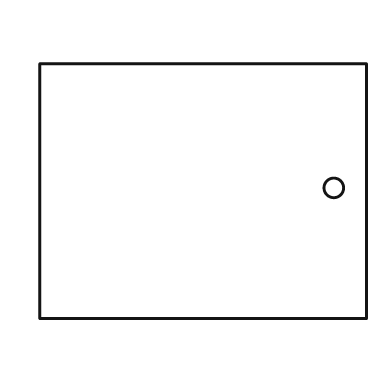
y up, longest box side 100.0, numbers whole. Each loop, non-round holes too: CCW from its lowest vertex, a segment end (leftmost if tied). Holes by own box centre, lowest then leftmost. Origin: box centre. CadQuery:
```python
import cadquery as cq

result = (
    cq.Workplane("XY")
    .moveTo(-50.0, -39.0)
    .lineTo(50.0, -39.0)
    .lineTo(50.0, 39.0)
    .lineTo(-50.0, 39.0)
    .close()
    .moveTo(40.0, 1.0)
    .circle(3.0)
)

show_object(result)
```